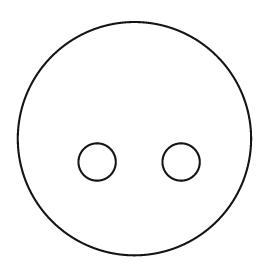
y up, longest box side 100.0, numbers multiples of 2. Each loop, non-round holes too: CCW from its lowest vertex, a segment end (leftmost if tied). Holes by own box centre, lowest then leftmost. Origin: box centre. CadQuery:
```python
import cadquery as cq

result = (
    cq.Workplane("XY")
    .moveTo(0.0, 0.0)
    .circle(50.0)
    .moveTo(-16.0, -10.0)
    .circle(8.0)
    .moveTo(20.0, -10.0)
    .circle(8.0)
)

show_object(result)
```